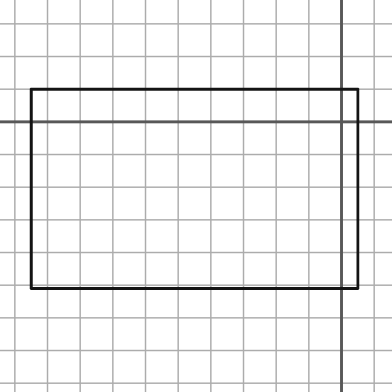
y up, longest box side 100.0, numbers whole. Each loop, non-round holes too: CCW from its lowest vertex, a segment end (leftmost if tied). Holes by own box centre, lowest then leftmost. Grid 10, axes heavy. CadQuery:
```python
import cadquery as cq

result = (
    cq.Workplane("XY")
    .moveTo(-95.0, -51.0)
    .lineTo(5.0, -51.0)
    .lineTo(5.0, 10.0)
    .lineTo(-95.0, 10.0)
    .close()
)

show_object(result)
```